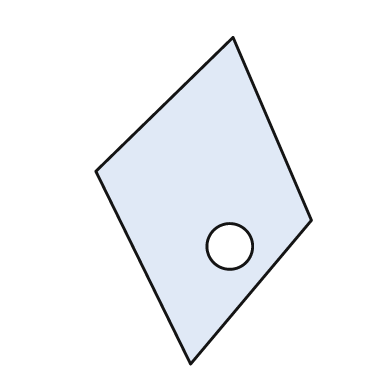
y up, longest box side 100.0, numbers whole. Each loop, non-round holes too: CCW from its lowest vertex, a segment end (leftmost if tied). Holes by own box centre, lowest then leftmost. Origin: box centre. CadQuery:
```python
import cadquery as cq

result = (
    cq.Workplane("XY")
    .moveTo(-4.0, -50.0)
    .lineTo(33.0, -6.0)
    .lineTo(9.0, 50.0)
    .lineTo(-33.0, 9.0)
    .close()
    .moveTo(8.0, -14.0)
    .circle(7.0)
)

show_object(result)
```